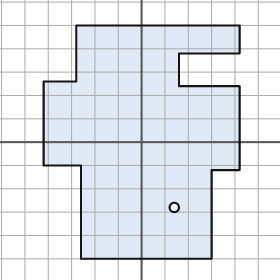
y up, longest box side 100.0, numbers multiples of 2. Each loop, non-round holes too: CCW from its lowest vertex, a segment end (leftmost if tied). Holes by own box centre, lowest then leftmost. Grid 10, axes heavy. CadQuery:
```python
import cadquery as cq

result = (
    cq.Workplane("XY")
    .moveTo(-26.0, -50.0)
    .lineTo(30.0, -50.0)
    .lineTo(30.0, -12.0)
    .lineTo(42.0, -12.0)
    .lineTo(42.0, 24.0)
    .lineTo(16.0, 24.0)
    .lineTo(16.0, 38.0)
    .lineTo(42.0, 38.0)
    .lineTo(42.0, 50.0)
    .lineTo(-28.0, 50.0)
    .lineTo(-28.0, 26.0)
    .lineTo(-42.0, 26.0)
    .lineTo(-42.0, -10.0)
    .lineTo(-26.0, -10.0)
    .close()
    .moveTo(14.0, -28.0)
    .circle(2.0)
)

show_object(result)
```